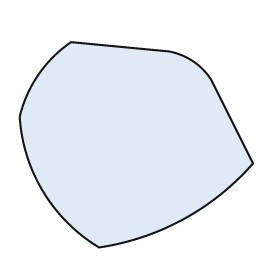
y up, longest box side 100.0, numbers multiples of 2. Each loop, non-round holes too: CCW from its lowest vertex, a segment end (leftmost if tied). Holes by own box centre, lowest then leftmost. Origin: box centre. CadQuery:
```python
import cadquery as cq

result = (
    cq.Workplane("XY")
    .moveTo(-16.0, -44.0)
    .threePointArc((20.0, -32.0), (50.0, -8.0))
    .lineTo(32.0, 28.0)
    .threePointArc((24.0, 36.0), (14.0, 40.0))
    .lineTo(-28.0, 44.0)
    .threePointArc((-42.0, 30.0), (-50.0, 12.0))
    .threePointArc((-40.0, -20.0), (-16.0, -44.0))
    .close()
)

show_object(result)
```